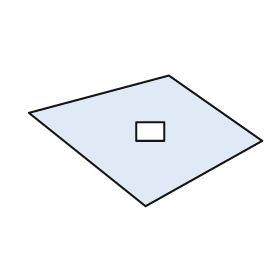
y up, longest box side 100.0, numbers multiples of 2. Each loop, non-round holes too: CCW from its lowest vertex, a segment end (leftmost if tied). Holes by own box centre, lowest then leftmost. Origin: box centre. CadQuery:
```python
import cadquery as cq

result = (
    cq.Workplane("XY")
    .moveTo(0.0, -28.0)
    .lineTo(50.0, 0.0)
    .lineTo(10.0, 28.0)
    .lineTo(-50.0, 12.0)
    .close()
    .moveTo(-4.0, 0.0)
    .lineTo(8.0, 0.0)
    .lineTo(8.0, 8.0)
    .lineTo(-4.0, 8.0)
    .close()
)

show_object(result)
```